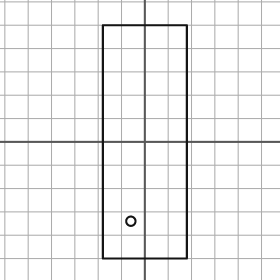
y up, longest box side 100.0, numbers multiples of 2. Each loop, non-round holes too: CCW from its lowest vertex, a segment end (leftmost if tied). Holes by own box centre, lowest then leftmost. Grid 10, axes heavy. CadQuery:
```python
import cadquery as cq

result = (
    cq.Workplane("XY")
    .moveTo(-18.0, -50.0)
    .lineTo(18.0, -50.0)
    .lineTo(18.0, 50.0)
    .lineTo(-18.0, 50.0)
    .close()
    .moveTo(-6.0, -34.0)
    .circle(2.0)
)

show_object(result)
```